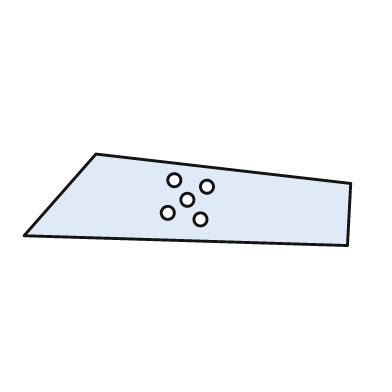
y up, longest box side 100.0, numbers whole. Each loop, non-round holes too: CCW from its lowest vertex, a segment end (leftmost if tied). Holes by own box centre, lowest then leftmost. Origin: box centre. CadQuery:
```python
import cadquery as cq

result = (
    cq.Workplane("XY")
    .moveTo(49.0, -14.0)
    .lineTo(50.0, 5.0)
    .lineTo(-28.0, 14.0)
    .lineTo(-50.0, -11.0)
    .close()
    .moveTo(4.0, -6.0)
    .circle(2.0)
    .moveTo(-6.0, -4.0)
    .circle(2.0)
    .moveTo(0.0, 0.0)
    .circle(2.0)
    .moveTo(6.0, 4.0)
    .circle(2.0)
    .moveTo(-4.0, 6.0)
    .circle(2.0)
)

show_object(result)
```